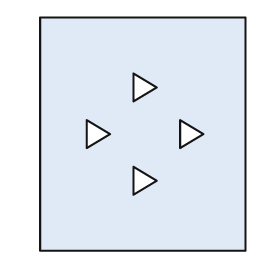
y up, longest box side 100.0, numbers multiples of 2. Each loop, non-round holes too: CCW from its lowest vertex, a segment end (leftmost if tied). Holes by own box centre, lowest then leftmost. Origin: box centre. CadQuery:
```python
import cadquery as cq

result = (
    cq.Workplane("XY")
    .moveTo(-44.0, -50.0)
    .lineTo(44.0, -50.0)
    .lineTo(44.0, 50.0)
    .lineTo(-44.0, 50.0)
    .close()
    .moveTo(-4.0, -26.0)
    .lineTo(6.0, -20.0)
    .lineTo(-4.0, -14.0)
    .close()
    .moveTo(-24.0, -6.0)
    .lineTo(-14.0, 0.0)
    .lineTo(-24.0, 6.0)
    .close()
    .moveTo(16.0, -6.0)
    .lineTo(26.0, 0.0)
    .lineTo(16.0, 6.0)
    .close()
    .moveTo(-4.0, 14.0)
    .lineTo(6.0, 20.0)
    .lineTo(-4.0, 26.0)
    .close()
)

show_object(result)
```